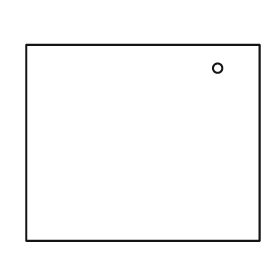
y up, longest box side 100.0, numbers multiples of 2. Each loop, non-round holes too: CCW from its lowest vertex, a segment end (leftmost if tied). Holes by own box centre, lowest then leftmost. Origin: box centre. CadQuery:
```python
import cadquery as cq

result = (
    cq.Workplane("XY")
    .moveTo(-50.0, -42.0)
    .lineTo(50.0, -42.0)
    .lineTo(50.0, 42.0)
    .lineTo(-50.0, 42.0)
    .close()
    .moveTo(32.0, 32.0)
    .circle(2.0)
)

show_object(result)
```